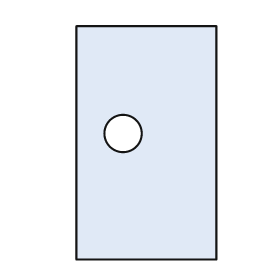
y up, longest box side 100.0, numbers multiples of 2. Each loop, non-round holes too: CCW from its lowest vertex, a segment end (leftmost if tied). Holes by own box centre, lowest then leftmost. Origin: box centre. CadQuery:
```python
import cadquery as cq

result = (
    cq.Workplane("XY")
    .moveTo(-30.0, -50.0)
    .lineTo(30.0, -50.0)
    .lineTo(30.0, 50.0)
    .lineTo(-30.0, 50.0)
    .close()
    .moveTo(-10.0, 4.0)
    .circle(8.0)
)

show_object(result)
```